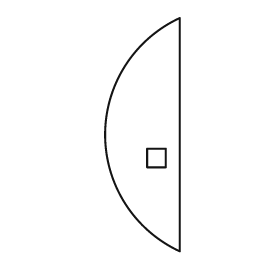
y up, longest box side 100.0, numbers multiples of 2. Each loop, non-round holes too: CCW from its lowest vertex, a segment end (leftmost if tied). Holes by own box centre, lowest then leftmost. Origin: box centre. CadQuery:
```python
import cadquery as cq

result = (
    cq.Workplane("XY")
    .moveTo(16.0, -50.0)
    .lineTo(16.0, 50.0)
    .threePointArc((-16.0, 0.0), (16.0, -50.0))
    .close()
    .moveTo(2.0, -14.0)
    .lineTo(10.0, -14.0)
    .lineTo(10.0, -6.0)
    .lineTo(2.0, -6.0)
    .close()
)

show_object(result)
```